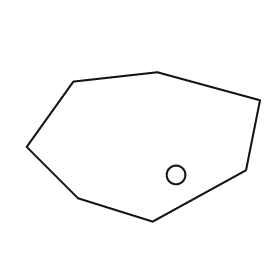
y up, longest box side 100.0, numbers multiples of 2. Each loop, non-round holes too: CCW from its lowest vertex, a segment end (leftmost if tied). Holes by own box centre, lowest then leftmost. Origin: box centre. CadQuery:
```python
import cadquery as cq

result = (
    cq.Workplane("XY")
    .moveTo(4.0, -32.0)
    .lineTo(44.0, -10.0)
    .lineTo(50.0, 20.0)
    .lineTo(6.0, 32.0)
    .lineTo(-30.0, 28.0)
    .lineTo(-50.0, 0.0)
    .lineTo(-28.0, -22.0)
    .close()
    .moveTo(14.0, -12.0)
    .circle(4.0)
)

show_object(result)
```